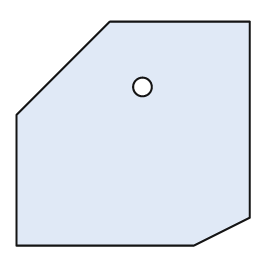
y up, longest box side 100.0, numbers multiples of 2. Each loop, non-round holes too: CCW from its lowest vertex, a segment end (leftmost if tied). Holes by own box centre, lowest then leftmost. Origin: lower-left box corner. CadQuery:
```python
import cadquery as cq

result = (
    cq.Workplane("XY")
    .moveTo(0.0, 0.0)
    .lineTo(76.0, 0.0)
    .lineTo(100.0, 12.0)
    .lineTo(100.0, 96.0)
    .lineTo(40.0, 96.0)
    .lineTo(0.0, 56.0)
    .close()
    .moveTo(54.0, 68.0)
    .circle(4.0)
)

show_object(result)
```